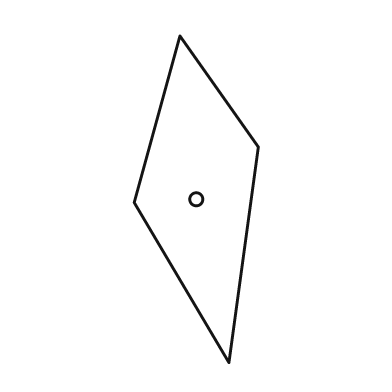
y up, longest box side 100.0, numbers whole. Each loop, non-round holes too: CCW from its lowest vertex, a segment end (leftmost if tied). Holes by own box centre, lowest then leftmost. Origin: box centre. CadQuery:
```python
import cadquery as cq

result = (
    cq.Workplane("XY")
    .moveTo(10.0, -50.0)
    .lineTo(19.0, 16.0)
    .lineTo(-5.0, 50.0)
    .lineTo(-19.0, -1.0)
    .close()
    .moveTo(0.0, 0.0)
    .circle(2.0)
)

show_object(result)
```